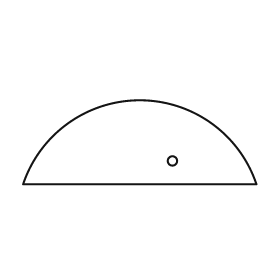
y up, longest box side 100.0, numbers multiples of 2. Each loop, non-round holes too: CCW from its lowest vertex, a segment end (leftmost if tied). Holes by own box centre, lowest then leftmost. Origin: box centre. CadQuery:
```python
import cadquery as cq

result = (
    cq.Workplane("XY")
    .moveTo(-50.0, -18.0)
    .lineTo(50.0, -18.0)
    .threePointArc((0.0, 18.0), (-50.0, -18.0))
    .close()
    .moveTo(14.0, -8.0)
    .circle(2.0)
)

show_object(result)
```